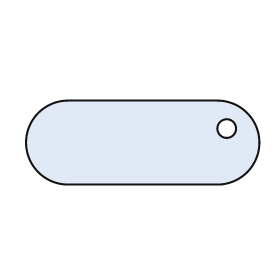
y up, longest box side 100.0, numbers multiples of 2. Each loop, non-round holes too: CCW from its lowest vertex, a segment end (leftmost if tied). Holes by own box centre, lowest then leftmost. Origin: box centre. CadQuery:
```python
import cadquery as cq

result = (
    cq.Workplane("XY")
    .moveTo(-32.0, -18.0)
    .lineTo(32.0, -18.0)
    .threePointArc((50.0, 0.0), (32.0, 18.0))
    .lineTo(-32.0, 18.0)
    .threePointArc((-50.0, 0.0), (-32.0, -18.0))
    .close()
    .moveTo(36.0, 6.0)
    .circle(4.0)
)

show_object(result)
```